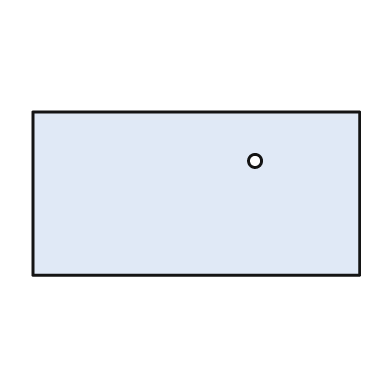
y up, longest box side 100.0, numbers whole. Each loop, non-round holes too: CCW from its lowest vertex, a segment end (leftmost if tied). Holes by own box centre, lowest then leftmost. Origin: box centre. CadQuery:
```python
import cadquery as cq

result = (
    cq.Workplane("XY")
    .moveTo(-50.0, -25.0)
    .lineTo(50.0, -25.0)
    .lineTo(50.0, 25.0)
    .lineTo(-50.0, 25.0)
    .close()
    .moveTo(18.0, 10.0)
    .circle(2.0)
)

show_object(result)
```